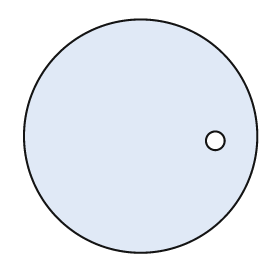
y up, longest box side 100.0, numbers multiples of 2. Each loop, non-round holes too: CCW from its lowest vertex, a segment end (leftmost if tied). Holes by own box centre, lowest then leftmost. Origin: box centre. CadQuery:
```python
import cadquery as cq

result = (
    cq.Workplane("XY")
    .moveTo(0.0, 0.0)
    .circle(50.0)
    .moveTo(32.0, -2.0)
    .circle(4.0)
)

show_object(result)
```